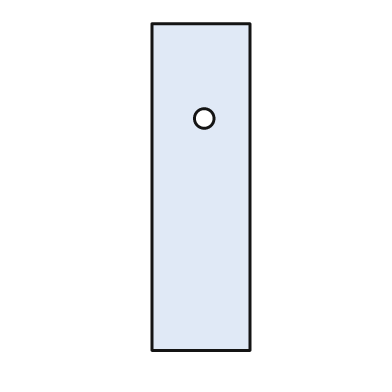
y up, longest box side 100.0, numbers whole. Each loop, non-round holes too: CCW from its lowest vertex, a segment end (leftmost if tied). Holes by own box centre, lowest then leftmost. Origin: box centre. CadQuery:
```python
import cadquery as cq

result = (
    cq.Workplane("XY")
    .moveTo(-15.0, -50.0)
    .lineTo(15.0, -50.0)
    .lineTo(15.0, 50.0)
    .lineTo(-15.0, 50.0)
    .close()
    .moveTo(1.0, 21.0)
    .circle(3.0)
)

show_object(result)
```